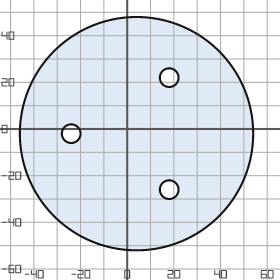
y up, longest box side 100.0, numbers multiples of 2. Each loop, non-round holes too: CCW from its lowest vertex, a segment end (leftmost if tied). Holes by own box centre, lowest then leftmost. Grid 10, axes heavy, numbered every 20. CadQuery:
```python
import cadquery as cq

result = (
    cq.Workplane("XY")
    .moveTo(4.0, -2.0)
    .circle(50.0)
    .moveTo(18.0, -26.0)
    .circle(4.0)
    .moveTo(-24.0, -2.0)
    .circle(4.0)
    .moveTo(18.0, 22.0)
    .circle(4.0)
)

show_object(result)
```